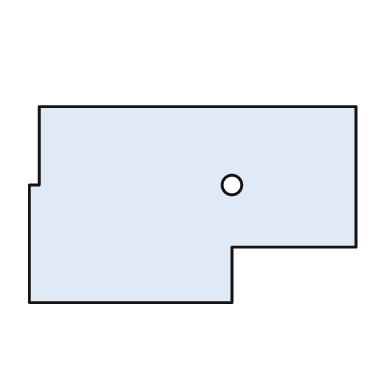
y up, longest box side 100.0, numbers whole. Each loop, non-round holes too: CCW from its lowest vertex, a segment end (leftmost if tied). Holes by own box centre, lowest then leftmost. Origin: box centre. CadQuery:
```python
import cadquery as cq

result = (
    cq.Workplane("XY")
    .moveTo(-50.0, -30.0)
    .lineTo(12.0, -30.0)
    .lineTo(12.0, -13.0)
    .lineTo(50.0, -13.0)
    .lineTo(50.0, 30.0)
    .lineTo(-47.0, 30.0)
    .lineTo(-47.0, 6.0)
    .lineTo(-50.0, 6.0)
    .close()
    .moveTo(12.0, 6.0)
    .circle(3.0)
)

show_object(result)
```